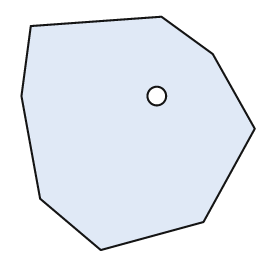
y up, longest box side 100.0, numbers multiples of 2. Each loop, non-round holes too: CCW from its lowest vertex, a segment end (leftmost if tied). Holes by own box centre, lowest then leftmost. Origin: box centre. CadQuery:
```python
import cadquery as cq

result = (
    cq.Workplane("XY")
    .moveTo(-16.0, -50.0)
    .lineTo(28.0, -38.0)
    .lineTo(50.0, 2.0)
    .lineTo(32.0, 34.0)
    .lineTo(10.0, 50.0)
    .lineTo(-46.0, 46.0)
    .lineTo(-50.0, 16.0)
    .lineTo(-42.0, -28.0)
    .close()
    .moveTo(8.0, 16.0)
    .circle(4.0)
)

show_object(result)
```